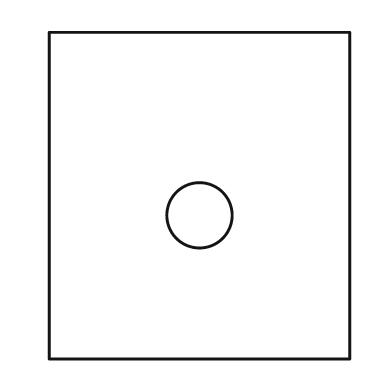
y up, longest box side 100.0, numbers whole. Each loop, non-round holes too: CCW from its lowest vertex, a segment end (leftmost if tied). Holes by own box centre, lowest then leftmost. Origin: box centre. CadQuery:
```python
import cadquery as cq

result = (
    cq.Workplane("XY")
    .moveTo(-46.0, -50.0)
    .lineTo(46.0, -50.0)
    .lineTo(46.0, 50.0)
    .lineTo(-46.0, 50.0)
    .close()
    .moveTo(0.0, -6.0)
    .circle(10.0)
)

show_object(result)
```